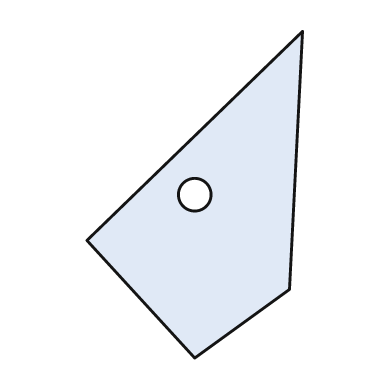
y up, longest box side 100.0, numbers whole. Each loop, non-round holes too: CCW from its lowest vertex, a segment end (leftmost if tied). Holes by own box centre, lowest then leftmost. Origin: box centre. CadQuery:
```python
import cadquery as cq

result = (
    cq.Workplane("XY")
    .moveTo(0.0, -50.0)
    .lineTo(29.0, -29.0)
    .lineTo(33.0, 50.0)
    .lineTo(-33.0, -14.0)
    .close()
    .moveTo(0.0, 0.0)
    .circle(5.0)
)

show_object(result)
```